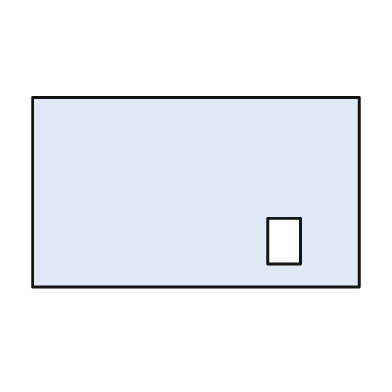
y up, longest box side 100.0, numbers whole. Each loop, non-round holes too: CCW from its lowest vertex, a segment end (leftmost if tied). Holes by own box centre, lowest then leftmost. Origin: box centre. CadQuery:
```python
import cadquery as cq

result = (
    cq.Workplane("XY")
    .moveTo(-50.0, -29.0)
    .lineTo(50.0, -29.0)
    .lineTo(50.0, 29.0)
    .lineTo(-50.0, 29.0)
    .close()
    .moveTo(22.0, -22.0)
    .lineTo(32.0, -22.0)
    .lineTo(32.0, -8.0)
    .lineTo(22.0, -8.0)
    .close()
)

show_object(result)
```